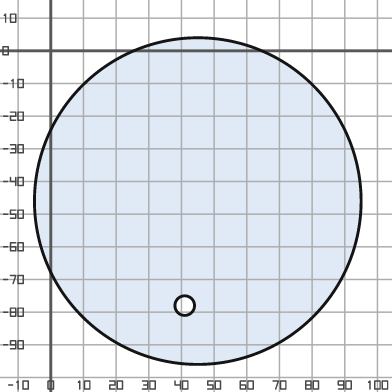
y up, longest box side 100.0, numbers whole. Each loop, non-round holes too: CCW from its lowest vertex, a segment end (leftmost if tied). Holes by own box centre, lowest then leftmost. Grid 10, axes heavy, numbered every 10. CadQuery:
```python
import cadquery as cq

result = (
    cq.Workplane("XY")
    .moveTo(45.0, -46.0)
    .circle(50.0)
    .moveTo(41.0, -78.0)
    .circle(3.0)
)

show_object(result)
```